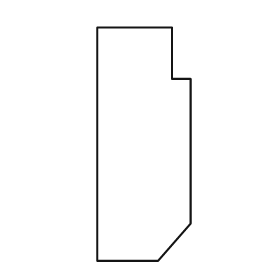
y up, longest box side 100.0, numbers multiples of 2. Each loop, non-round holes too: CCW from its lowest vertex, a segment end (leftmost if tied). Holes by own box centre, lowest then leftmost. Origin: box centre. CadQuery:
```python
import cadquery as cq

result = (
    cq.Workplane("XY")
    .moveTo(-20.0, -50.0)
    .lineTo(6.0, -50.0)
    .lineTo(20.0, -34.0)
    .lineTo(20.0, 28.0)
    .lineTo(12.0, 28.0)
    .lineTo(12.0, 50.0)
    .lineTo(-20.0, 50.0)
    .close()
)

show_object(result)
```